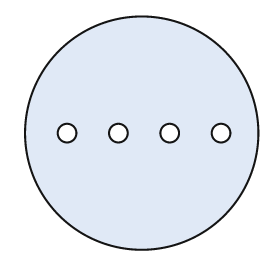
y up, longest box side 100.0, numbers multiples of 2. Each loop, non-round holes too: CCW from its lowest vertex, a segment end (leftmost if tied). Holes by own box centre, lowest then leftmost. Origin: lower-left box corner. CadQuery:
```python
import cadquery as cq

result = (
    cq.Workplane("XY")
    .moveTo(50.0, 50.0)
    .circle(50.0)
    .moveTo(18.0, 50.0)
    .circle(4.0)
    .moveTo(40.0, 50.0)
    .circle(4.0)
    .moveTo(62.0, 50.0)
    .circle(4.0)
    .moveTo(84.0, 50.0)
    .circle(4.0)
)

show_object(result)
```